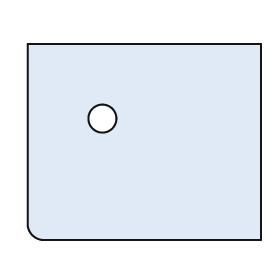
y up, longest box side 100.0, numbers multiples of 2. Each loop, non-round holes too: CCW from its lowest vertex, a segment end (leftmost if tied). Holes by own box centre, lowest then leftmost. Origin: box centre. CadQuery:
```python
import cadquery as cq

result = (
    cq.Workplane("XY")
    .moveTo(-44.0, -42.0)
    .lineTo(50.0, -42.0)
    .lineTo(50.0, 42.0)
    .lineTo(-50.0, 42.0)
    .lineTo(-50.0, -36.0)
    .threePointArc((-48.0, -40.0), (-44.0, -42.0))
    .close()
    .moveTo(-18.0, 10.0)
    .circle(6.0)
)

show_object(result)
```